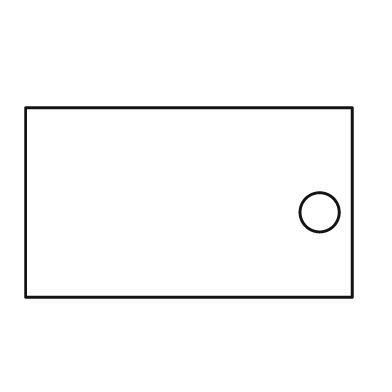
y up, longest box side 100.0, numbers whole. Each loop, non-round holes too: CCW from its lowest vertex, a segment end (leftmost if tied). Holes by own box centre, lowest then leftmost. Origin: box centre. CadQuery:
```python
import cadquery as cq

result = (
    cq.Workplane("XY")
    .moveTo(-50.0, -29.0)
    .lineTo(50.0, -29.0)
    .lineTo(50.0, 29.0)
    .lineTo(-50.0, 29.0)
    .close()
    .moveTo(40.0, -3.0)
    .circle(6.0)
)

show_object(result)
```